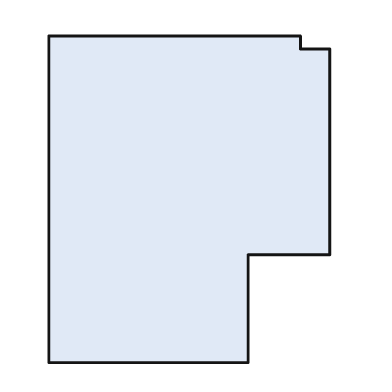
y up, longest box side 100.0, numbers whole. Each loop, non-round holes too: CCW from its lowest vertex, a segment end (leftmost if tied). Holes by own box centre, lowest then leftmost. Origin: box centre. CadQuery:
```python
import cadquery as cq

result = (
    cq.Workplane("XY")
    .moveTo(-43.0, -50.0)
    .lineTo(18.0, -50.0)
    .lineTo(18.0, -17.0)
    .lineTo(43.0, -17.0)
    .lineTo(43.0, 46.0)
    .lineTo(34.0, 46.0)
    .lineTo(34.0, 50.0)
    .lineTo(-43.0, 50.0)
    .close()
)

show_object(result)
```